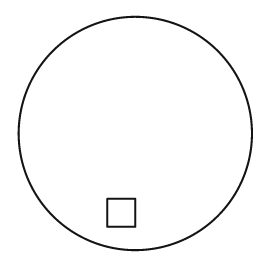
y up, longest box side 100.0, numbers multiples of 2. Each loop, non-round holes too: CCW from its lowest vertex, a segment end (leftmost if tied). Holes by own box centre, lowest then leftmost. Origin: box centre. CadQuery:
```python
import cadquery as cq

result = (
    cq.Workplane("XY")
    .moveTo(0.0, 0.0)
    .circle(50.0)
    .moveTo(-12.0, -40.0)
    .lineTo(0.0, -40.0)
    .lineTo(0.0, -28.0)
    .lineTo(-12.0, -28.0)
    .close()
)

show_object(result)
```